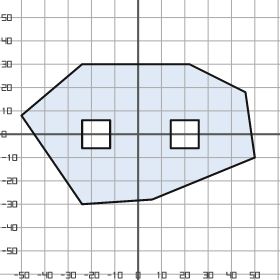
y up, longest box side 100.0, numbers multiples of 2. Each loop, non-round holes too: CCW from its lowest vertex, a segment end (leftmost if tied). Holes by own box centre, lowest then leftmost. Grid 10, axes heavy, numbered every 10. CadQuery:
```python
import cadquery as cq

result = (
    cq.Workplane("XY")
    .moveTo(-24.0, -30.0)
    .lineTo(6.0, -28.0)
    .lineTo(50.0, -10.0)
    .lineTo(46.0, 18.0)
    .lineTo(22.0, 30.0)
    .lineTo(-24.0, 30.0)
    .lineTo(-50.0, 8.0)
    .close()
    .moveTo(-24.0, -6.0)
    .lineTo(-12.0, -6.0)
    .lineTo(-12.0, 6.0)
    .lineTo(-24.0, 6.0)
    .close()
    .moveTo(14.0, -6.0)
    .lineTo(26.0, -6.0)
    .lineTo(26.0, 6.0)
    .lineTo(14.0, 6.0)
    .close()
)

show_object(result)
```